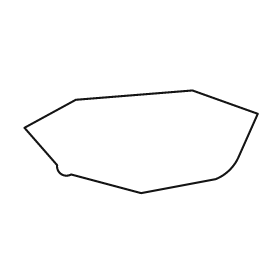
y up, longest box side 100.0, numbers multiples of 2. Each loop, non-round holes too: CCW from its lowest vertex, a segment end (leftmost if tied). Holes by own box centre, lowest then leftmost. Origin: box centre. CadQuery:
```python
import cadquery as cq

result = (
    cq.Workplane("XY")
    .moveTo(0.0, -22.0)
    .lineTo(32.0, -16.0)
    .threePointArc((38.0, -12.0), (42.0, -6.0))
    .lineTo(50.0, 12.0)
    .lineTo(22.0, 22.0)
    .lineTo(-28.0, 18.0)
    .lineTo(-50.0, 6.0)
    .lineTo(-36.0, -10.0)
    .threePointArc((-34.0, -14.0), (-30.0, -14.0))
    .close()
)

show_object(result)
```